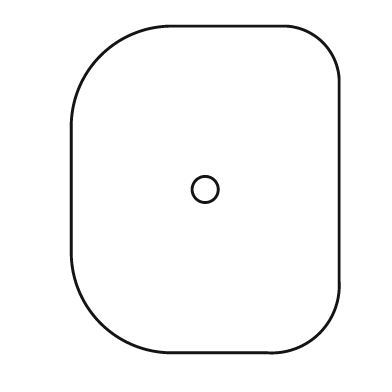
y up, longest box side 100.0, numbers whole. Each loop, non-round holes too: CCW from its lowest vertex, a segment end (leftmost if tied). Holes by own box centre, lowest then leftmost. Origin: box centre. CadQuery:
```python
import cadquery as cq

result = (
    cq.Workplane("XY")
    .moveTo(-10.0, -50.0)
    .lineTo(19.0, -50.0)
    .threePointArc((35.0, -44.0), (41.0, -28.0))
    .lineTo(41.0, 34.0)
    .threePointArc((36.0, 45.0), (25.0, 50.0))
    .lineTo(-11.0, 50.0)
    .threePointArc((-32.0, 41.0), (-41.0, 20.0))
    .lineTo(-41.0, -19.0)
    .threePointArc((-32.0, -41.0), (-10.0, -50.0))
    .close()
    .moveTo(0.0, 0.0)
    .circle(4.0)
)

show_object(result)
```